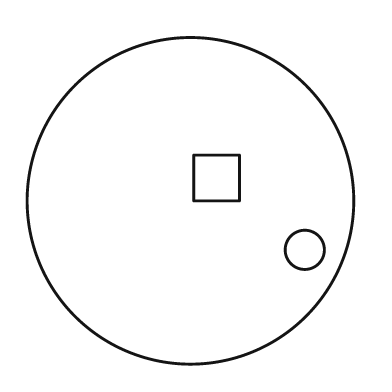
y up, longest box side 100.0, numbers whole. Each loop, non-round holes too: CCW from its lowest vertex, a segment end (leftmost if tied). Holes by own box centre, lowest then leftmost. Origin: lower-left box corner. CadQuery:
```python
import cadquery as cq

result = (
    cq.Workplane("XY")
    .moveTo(50.0, 50.0)
    .circle(50.0)
    .moveTo(85.0, 35.0)
    .circle(6.0)
    .moveTo(51.0, 50.0)
    .lineTo(65.0, 50.0)
    .lineTo(65.0, 64.0)
    .lineTo(51.0, 64.0)
    .close()
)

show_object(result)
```